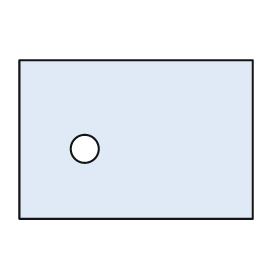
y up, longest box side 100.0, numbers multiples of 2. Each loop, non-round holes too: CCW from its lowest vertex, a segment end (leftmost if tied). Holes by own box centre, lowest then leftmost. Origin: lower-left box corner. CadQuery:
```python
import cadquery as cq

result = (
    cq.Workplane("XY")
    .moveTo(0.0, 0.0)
    .lineTo(100.0, 0.0)
    .lineTo(100.0, 68.0)
    .lineTo(0.0, 68.0)
    .close()
    .moveTo(28.0, 30.0)
    .circle(6.0)
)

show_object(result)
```